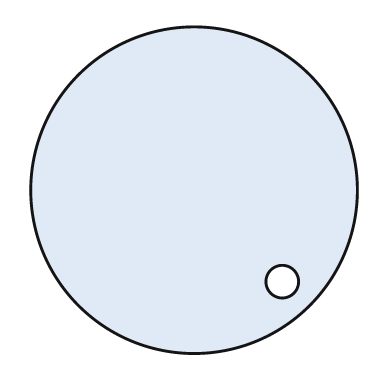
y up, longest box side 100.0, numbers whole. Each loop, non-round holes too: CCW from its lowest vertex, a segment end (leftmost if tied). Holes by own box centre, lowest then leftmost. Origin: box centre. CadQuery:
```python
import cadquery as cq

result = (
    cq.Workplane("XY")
    .moveTo(0.0, 0.0)
    .circle(50.0)
    .moveTo(27.0, -28.0)
    .circle(5.0)
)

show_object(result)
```